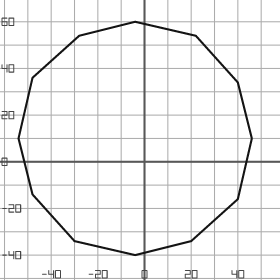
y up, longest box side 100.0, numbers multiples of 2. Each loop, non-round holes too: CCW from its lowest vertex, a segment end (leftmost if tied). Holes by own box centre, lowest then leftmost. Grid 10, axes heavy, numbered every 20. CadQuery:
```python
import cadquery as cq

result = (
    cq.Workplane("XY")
    .moveTo(-4.0, -40.0)
    .lineTo(20.0, -34.0)
    .lineTo(40.0, -16.0)
    .lineTo(46.0, 10.0)
    .lineTo(40.0, 34.0)
    .lineTo(22.0, 54.0)
    .lineTo(-4.0, 60.0)
    .lineTo(-28.0, 54.0)
    .lineTo(-48.0, 36.0)
    .lineTo(-54.0, 10.0)
    .lineTo(-48.0, -14.0)
    .lineTo(-30.0, -34.0)
    .close()
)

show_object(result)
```